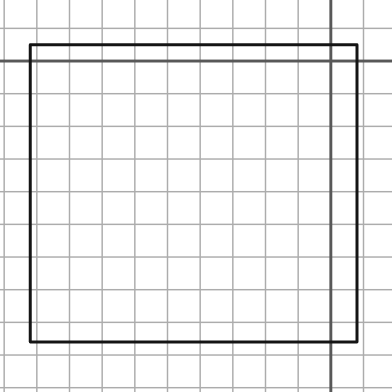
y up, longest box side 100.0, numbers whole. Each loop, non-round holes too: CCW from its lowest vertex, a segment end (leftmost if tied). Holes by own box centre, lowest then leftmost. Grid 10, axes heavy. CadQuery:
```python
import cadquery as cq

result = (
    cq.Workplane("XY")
    .moveTo(-92.0, -86.0)
    .lineTo(8.0, -86.0)
    .lineTo(8.0, 5.0)
    .lineTo(-92.0, 5.0)
    .close()
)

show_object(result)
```